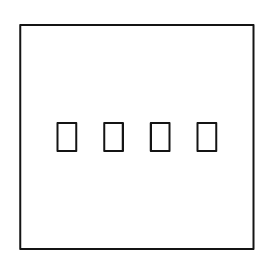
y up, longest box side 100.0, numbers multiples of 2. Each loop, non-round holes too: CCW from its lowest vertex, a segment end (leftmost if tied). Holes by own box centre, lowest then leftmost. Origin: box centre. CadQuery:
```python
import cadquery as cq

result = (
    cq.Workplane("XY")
    .moveTo(-50.0, -48.0)
    .lineTo(50.0, -48.0)
    .lineTo(50.0, 48.0)
    .lineTo(-50.0, 48.0)
    .close()
    .moveTo(-34.0, -6.0)
    .lineTo(-26.0, -6.0)
    .lineTo(-26.0, 6.0)
    .lineTo(-34.0, 6.0)
    .close()
    .moveTo(-14.0, -6.0)
    .lineTo(-6.0, -6.0)
    .lineTo(-6.0, 6.0)
    .lineTo(-14.0, 6.0)
    .close()
    .moveTo(6.0, -6.0)
    .lineTo(14.0, -6.0)
    .lineTo(14.0, 6.0)
    .lineTo(6.0, 6.0)
    .close()
    .moveTo(26.0, -6.0)
    .lineTo(34.0, -6.0)
    .lineTo(34.0, 6.0)
    .lineTo(26.0, 6.0)
    .close()
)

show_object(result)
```